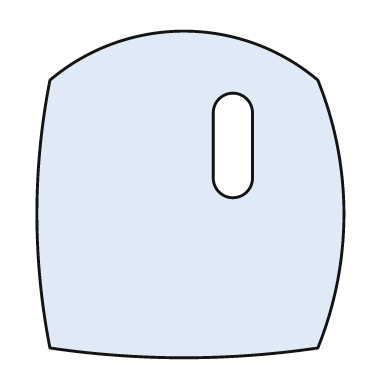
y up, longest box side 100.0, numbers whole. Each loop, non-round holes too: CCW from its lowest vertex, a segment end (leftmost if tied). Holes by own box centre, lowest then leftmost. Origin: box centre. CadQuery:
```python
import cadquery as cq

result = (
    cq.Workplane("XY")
    .moveTo(-43.0, -47.0)
    .threePointArc((-2.0, -50.0), (39.0, -47.0))
    .threePointArc((47.0, -6.0), (39.0, 35.0))
    .threePointArc((-2.0, 50.0), (-43.0, 35.0))
    .threePointArc((-47.0, -6.0), (-43.0, -47.0))
    .close()
    .moveTo(7.0, 5.0)
    .threePointArc((13.0, -1.0), (19.0, 5.0))
    .lineTo(19.0, 25.0)
    .threePointArc((13.0, 31.0), (7.0, 25.0))
    .close()
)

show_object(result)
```